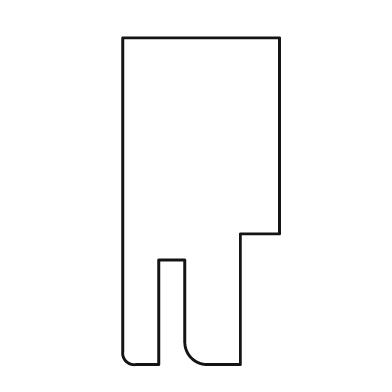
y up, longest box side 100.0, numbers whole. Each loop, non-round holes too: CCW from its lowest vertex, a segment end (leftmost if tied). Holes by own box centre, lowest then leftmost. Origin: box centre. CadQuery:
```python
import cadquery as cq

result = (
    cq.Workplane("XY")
    .moveTo(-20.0, -50.0)
    .lineTo(-13.0, -50.0)
    .lineTo(-13.0, -18.0)
    .lineTo(-5.0, -18.0)
    .lineTo(-5.0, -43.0)
    .threePointArc((-3.0, -48.0), (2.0, -50.0))
    .lineTo(12.0, -50.0)
    .lineTo(12.0, -10.0)
    .lineTo(24.0, -10.0)
    .lineTo(24.0, 50.0)
    .lineTo(-24.0, 50.0)
    .lineTo(-24.0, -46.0)
    .threePointArc((-23.0, -49.0), (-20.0, -50.0))
    .close()
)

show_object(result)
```